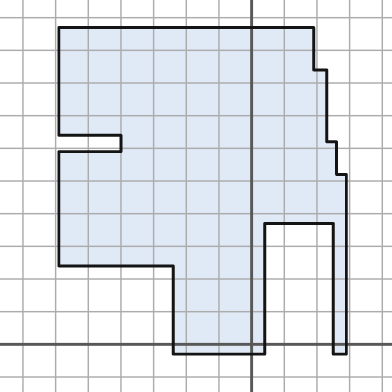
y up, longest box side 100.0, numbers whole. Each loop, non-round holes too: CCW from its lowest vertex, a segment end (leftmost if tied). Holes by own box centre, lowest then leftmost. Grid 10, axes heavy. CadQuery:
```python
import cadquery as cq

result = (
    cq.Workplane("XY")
    .moveTo(-24.0, -3.0)
    .lineTo(4.0, -3.0)
    .lineTo(4.0, 37.0)
    .lineTo(25.0, 37.0)
    .lineTo(25.0, -3.0)
    .lineTo(29.0, -3.0)
    .lineTo(29.0, 52.0)
    .lineTo(26.0, 52.0)
    .lineTo(26.0, 62.0)
    .lineTo(23.0, 62.0)
    .lineTo(23.0, 84.0)
    .lineTo(19.0, 84.0)
    .lineTo(19.0, 97.0)
    .lineTo(-59.0, 97.0)
    .lineTo(-59.0, 64.0)
    .lineTo(-40.0, 64.0)
    .lineTo(-40.0, 59.0)
    .lineTo(-59.0, 59.0)
    .lineTo(-59.0, 24.0)
    .lineTo(-24.0, 24.0)
    .close()
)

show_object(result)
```